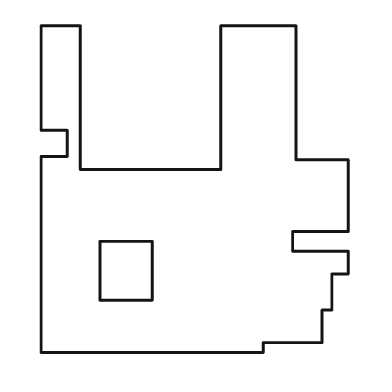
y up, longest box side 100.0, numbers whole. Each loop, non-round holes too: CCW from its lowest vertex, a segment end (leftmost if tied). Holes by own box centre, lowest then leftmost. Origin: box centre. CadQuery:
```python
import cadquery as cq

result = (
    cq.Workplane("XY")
    .moveTo(-47.0, -50.0)
    .lineTo(21.0, -50.0)
    .lineTo(21.0, -47.0)
    .lineTo(39.0, -47.0)
    .lineTo(39.0, -37.0)
    .lineTo(42.0, -37.0)
    .lineTo(42.0, -26.0)
    .lineTo(47.0, -26.0)
    .lineTo(47.0, -19.0)
    .lineTo(30.0, -19.0)
    .lineTo(30.0, -13.0)
    .lineTo(47.0, -13.0)
    .lineTo(47.0, 9.0)
    .lineTo(31.0, 9.0)
    .lineTo(31.0, 50.0)
    .lineTo(8.0, 50.0)
    .lineTo(8.0, 6.0)
    .lineTo(-35.0, 6.0)
    .lineTo(-35.0, 50.0)
    .lineTo(-47.0, 50.0)
    .lineTo(-47.0, 18.0)
    .lineTo(-39.0, 18.0)
    .lineTo(-39.0, 10.0)
    .lineTo(-47.0, 10.0)
    .close()
    .moveTo(-29.0, -34.0)
    .lineTo(-13.0, -34.0)
    .lineTo(-13.0, -16.0)
    .lineTo(-29.0, -16.0)
    .close()
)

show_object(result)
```